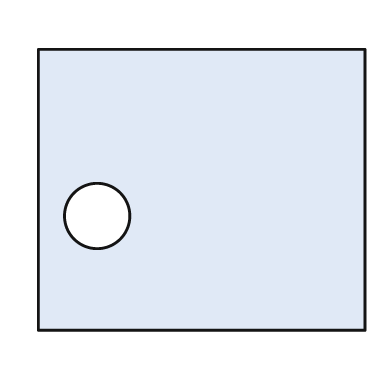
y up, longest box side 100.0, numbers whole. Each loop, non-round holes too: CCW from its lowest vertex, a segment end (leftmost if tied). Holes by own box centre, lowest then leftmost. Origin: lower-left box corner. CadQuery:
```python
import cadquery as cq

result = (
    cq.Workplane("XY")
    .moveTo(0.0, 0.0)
    .lineTo(100.0, 0.0)
    .lineTo(100.0, 86.0)
    .lineTo(0.0, 86.0)
    .close()
    .moveTo(18.0, 35.0)
    .circle(10.0)
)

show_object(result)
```